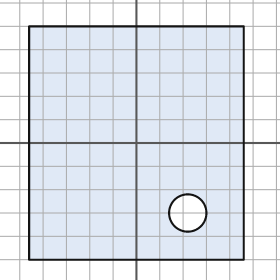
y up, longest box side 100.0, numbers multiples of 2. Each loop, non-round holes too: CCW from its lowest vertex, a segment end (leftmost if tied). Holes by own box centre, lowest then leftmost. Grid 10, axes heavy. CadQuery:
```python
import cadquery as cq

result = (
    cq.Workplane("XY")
    .moveTo(-46.0, -50.0)
    .lineTo(46.0, -50.0)
    .lineTo(46.0, 50.0)
    .lineTo(-46.0, 50.0)
    .close()
    .moveTo(22.0, -30.0)
    .circle(8.0)
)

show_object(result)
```